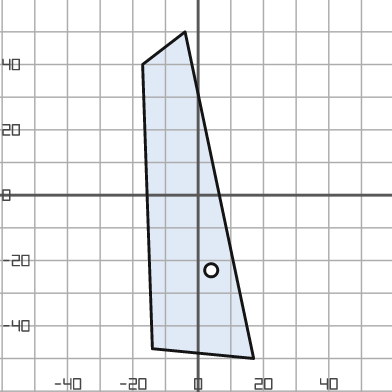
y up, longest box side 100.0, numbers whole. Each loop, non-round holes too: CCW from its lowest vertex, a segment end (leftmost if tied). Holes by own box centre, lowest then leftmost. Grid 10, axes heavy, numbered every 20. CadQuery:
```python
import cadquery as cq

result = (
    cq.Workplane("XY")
    .moveTo(17.0, -50.0)
    .lineTo(-4.0, 50.0)
    .lineTo(-17.0, 40.0)
    .lineTo(-14.0, -47.0)
    .close()
    .moveTo(4.0, -23.0)
    .circle(2.0)
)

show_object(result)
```